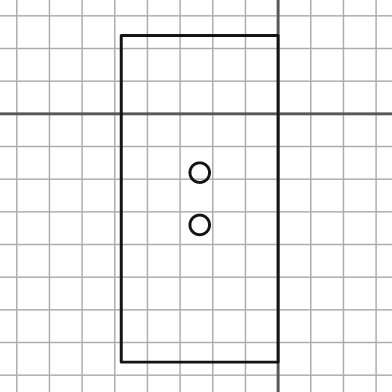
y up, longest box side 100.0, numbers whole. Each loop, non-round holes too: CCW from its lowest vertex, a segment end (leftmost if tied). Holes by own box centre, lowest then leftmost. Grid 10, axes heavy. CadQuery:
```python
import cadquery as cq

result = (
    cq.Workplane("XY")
    .moveTo(-48.0, -76.0)
    .lineTo(0.0, -76.0)
    .lineTo(0.0, 24.0)
    .lineTo(-48.0, 24.0)
    .close()
    .moveTo(-24.0, -34.0)
    .circle(3.0)
    .moveTo(-24.0, -18.0)
    .circle(3.0)
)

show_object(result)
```